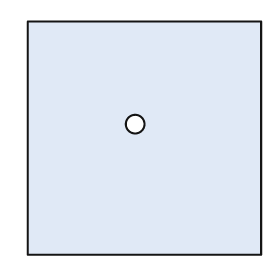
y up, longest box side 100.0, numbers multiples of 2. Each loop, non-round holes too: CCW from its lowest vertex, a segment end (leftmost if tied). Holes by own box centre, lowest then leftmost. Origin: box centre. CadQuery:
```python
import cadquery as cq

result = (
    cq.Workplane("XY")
    .moveTo(-50.0, -50.0)
    .lineTo(50.0, -50.0)
    .lineTo(50.0, 50.0)
    .lineTo(-50.0, 50.0)
    .close()
    .moveTo(-4.0, 6.0)
    .circle(4.0)
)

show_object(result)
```